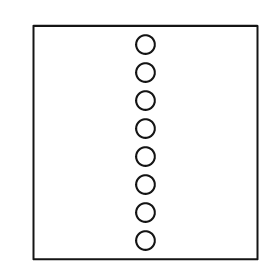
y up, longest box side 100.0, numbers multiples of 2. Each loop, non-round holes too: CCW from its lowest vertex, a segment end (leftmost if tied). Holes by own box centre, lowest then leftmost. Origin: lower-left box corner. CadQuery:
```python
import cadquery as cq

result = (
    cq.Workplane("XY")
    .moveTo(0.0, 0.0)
    .lineTo(96.0, 0.0)
    .lineTo(96.0, 100.0)
    .lineTo(0.0, 100.0)
    .close()
    .moveTo(48.0, 8.0)
    .circle(4.0)
    .moveTo(48.0, 20.0)
    .circle(4.0)
    .moveTo(48.0, 32.0)
    .circle(4.0)
    .moveTo(48.0, 44.0)
    .circle(4.0)
    .moveTo(48.0, 56.0)
    .circle(4.0)
    .moveTo(48.0, 68.0)
    .circle(4.0)
    .moveTo(48.0, 80.0)
    .circle(4.0)
    .moveTo(48.0, 92.0)
    .circle(4.0)
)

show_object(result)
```